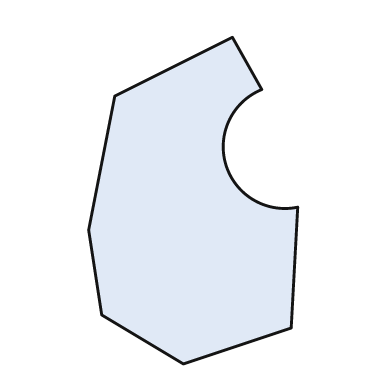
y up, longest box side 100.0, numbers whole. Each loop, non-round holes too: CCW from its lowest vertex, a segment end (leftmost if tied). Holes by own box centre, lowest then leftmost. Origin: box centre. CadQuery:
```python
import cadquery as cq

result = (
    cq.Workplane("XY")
    .moveTo(-3.0, -50.0)
    .lineTo(30.0, -39.0)
    .lineTo(32.0, -2.0)
    .threePointArc((10.0, 11.0), (21.0, 34.0))
    .lineTo(12.0, 50.0)
    .lineTo(-24.0, 32.0)
    .lineTo(-32.0, -9.0)
    .lineTo(-28.0, -35.0)
    .close()
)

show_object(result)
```